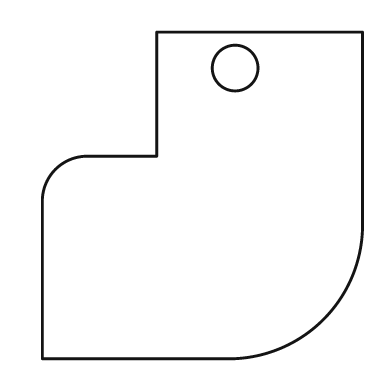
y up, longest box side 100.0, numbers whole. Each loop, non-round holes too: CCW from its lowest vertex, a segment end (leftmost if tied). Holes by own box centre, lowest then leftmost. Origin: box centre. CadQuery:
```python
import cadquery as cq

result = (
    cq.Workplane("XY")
    .moveTo(-49.0, -50.0)
    .lineTo(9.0, -50.0)
    .threePointArc((37.0, -38.0), (49.0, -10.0))
    .lineTo(49.0, 50.0)
    .lineTo(-14.0, 50.0)
    .lineTo(-14.0, 12.0)
    .lineTo(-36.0, 12.0)
    .threePointArc((-45.0, 8.0), (-49.0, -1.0))
    .close()
    .moveTo(10.0, 39.0)
    .circle(7.0)
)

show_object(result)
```